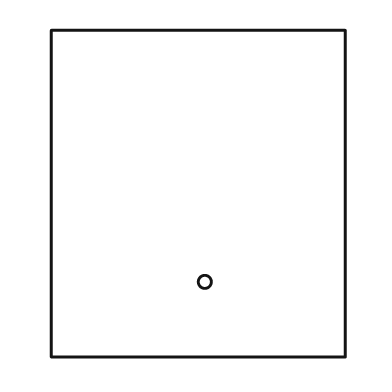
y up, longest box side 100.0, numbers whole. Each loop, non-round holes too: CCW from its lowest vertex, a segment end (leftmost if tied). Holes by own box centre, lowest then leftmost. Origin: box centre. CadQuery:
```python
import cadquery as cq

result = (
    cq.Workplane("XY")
    .moveTo(-45.0, -50.0)
    .lineTo(45.0, -50.0)
    .lineTo(45.0, 50.0)
    .lineTo(-45.0, 50.0)
    .close()
    .moveTo(2.0, -27.0)
    .circle(2.0)
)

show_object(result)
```